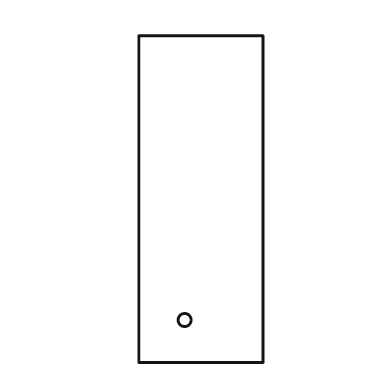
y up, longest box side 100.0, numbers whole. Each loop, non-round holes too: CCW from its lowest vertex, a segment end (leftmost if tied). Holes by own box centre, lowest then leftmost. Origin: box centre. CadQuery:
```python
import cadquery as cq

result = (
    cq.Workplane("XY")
    .moveTo(-19.0, -50.0)
    .lineTo(19.0, -50.0)
    .lineTo(19.0, 50.0)
    .lineTo(-19.0, 50.0)
    .close()
    .moveTo(-5.0, -37.0)
    .circle(2.0)
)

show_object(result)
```